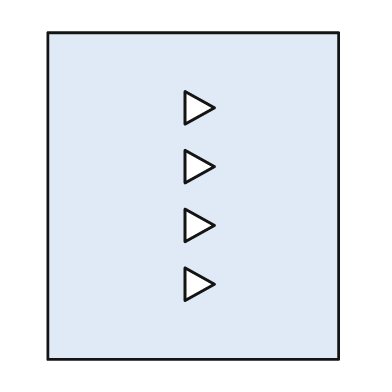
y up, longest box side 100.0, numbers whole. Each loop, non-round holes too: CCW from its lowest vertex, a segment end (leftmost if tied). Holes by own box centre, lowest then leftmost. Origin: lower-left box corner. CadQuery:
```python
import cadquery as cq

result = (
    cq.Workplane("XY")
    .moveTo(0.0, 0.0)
    .lineTo(89.0, 0.0)
    .lineTo(89.0, 100.0)
    .lineTo(0.0, 100.0)
    .close()
    .moveTo(42.0, 18.0)
    .lineTo(51.0, 23.0)
    .lineTo(42.0, 28.0)
    .close()
    .moveTo(42.0, 36.0)
    .lineTo(51.0, 41.0)
    .lineTo(42.0, 46.0)
    .close()
    .moveTo(42.0, 54.0)
    .lineTo(51.0, 59.0)
    .lineTo(42.0, 64.0)
    .close()
    .moveTo(42.0, 72.0)
    .lineTo(51.0, 77.0)
    .lineTo(42.0, 82.0)
    .close()
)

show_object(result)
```